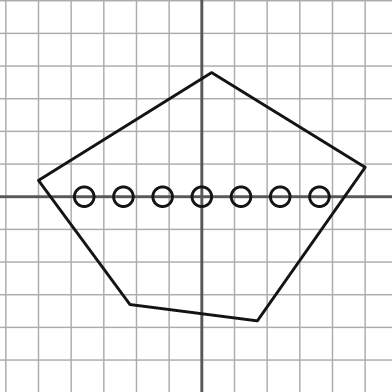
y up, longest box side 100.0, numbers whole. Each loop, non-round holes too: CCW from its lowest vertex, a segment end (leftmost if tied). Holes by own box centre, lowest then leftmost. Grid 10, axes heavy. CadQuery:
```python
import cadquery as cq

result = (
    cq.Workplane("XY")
    .moveTo(17.0, -38.0)
    .lineTo(50.0, 9.0)
    .lineTo(3.0, 38.0)
    .lineTo(-50.0, 5.0)
    .lineTo(-22.0, -33.0)
    .close()
    .moveTo(-36.0, 0.0)
    .circle(3.0)
    .moveTo(-24.0, 0.0)
    .circle(3.0)
    .moveTo(-12.0, 0.0)
    .circle(3.0)
    .moveTo(0.0, 0.0)
    .circle(3.0)
    .moveTo(12.0, 0.0)
    .circle(3.0)
    .moveTo(24.0, 0.0)
    .circle(3.0)
    .moveTo(36.0, 0.0)
    .circle(3.0)
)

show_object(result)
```